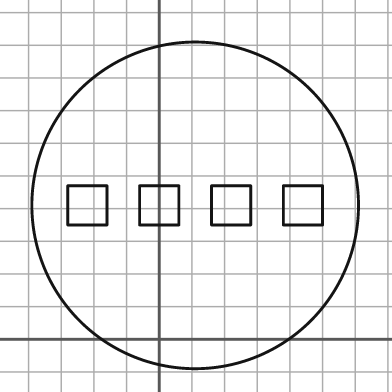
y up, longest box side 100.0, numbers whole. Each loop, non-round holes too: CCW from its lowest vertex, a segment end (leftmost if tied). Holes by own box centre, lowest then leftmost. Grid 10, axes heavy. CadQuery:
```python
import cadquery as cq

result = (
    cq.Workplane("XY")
    .moveTo(11.0, 41.0)
    .circle(50.0)
    .moveTo(-28.0, 35.0)
    .lineTo(-16.0, 35.0)
    .lineTo(-16.0, 47.0)
    .lineTo(-28.0, 47.0)
    .close()
    .moveTo(-6.0, 35.0)
    .lineTo(6.0, 35.0)
    .lineTo(6.0, 47.0)
    .lineTo(-6.0, 47.0)
    .close()
    .moveTo(16.0, 35.0)
    .lineTo(28.0, 35.0)
    .lineTo(28.0, 47.0)
    .lineTo(16.0, 47.0)
    .close()
    .moveTo(38.0, 35.0)
    .lineTo(50.0, 35.0)
    .lineTo(50.0, 47.0)
    .lineTo(38.0, 47.0)
    .close()
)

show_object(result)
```